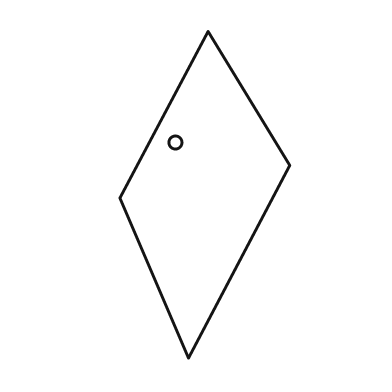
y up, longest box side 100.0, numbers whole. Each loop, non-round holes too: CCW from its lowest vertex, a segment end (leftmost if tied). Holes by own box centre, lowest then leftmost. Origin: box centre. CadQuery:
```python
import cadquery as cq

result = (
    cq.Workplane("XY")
    .moveTo(-5.0, -50.0)
    .lineTo(26.0, 9.0)
    .lineTo(1.0, 50.0)
    .lineTo(-26.0, -1.0)
    .close()
    .moveTo(-9.0, 16.0)
    .circle(2.0)
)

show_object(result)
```